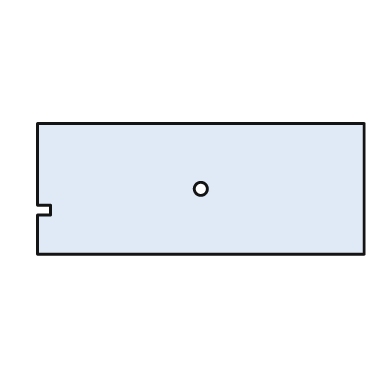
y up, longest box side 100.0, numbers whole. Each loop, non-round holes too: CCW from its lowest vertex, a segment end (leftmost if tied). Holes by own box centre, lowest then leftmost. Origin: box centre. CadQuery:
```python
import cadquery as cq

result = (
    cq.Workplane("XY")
    .moveTo(-50.0, -20.0)
    .lineTo(50.0, -20.0)
    .lineTo(50.0, 20.0)
    .lineTo(-50.0, 20.0)
    .lineTo(-50.0, -5.0)
    .lineTo(-46.0, -5.0)
    .lineTo(-46.0, -8.0)
    .lineTo(-50.0, -8.0)
    .close()
    .moveTo(0.0, 0.0)
    .circle(2.0)
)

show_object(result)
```